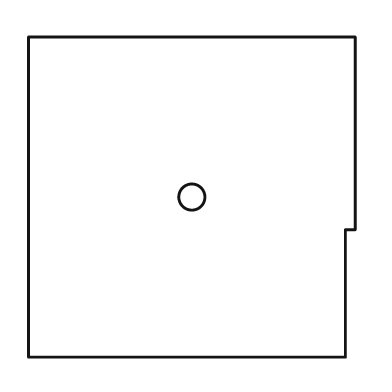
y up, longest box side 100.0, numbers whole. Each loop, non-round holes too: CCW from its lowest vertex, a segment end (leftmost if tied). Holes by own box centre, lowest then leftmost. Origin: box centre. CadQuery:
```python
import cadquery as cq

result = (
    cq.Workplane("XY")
    .moveTo(-50.0, -49.0)
    .lineTo(47.0, -49.0)
    .lineTo(47.0, -10.0)
    .lineTo(50.0, -10.0)
    .lineTo(50.0, 49.0)
    .lineTo(-50.0, 49.0)
    .close()
    .moveTo(0.0, 0.0)
    .circle(4.0)
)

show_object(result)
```